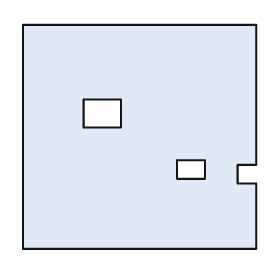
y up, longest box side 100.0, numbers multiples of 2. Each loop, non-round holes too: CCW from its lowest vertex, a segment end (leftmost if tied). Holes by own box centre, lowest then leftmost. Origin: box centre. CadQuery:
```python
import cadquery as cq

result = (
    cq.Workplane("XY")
    .moveTo(-50.0, -48.0)
    .lineTo(50.0, -48.0)
    .lineTo(50.0, -20.0)
    .lineTo(42.0, -20.0)
    .lineTo(42.0, -12.0)
    .lineTo(50.0, -12.0)
    .lineTo(50.0, 48.0)
    .lineTo(-50.0, 48.0)
    .close()
    .moveTo(16.0, -18.0)
    .lineTo(28.0, -18.0)
    .lineTo(28.0, -10.0)
    .lineTo(16.0, -10.0)
    .close()
    .moveTo(-24.0, 4.0)
    .lineTo(-8.0, 4.0)
    .lineTo(-8.0, 16.0)
    .lineTo(-24.0, 16.0)
    .close()
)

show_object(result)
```